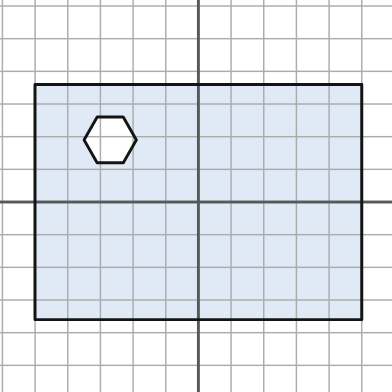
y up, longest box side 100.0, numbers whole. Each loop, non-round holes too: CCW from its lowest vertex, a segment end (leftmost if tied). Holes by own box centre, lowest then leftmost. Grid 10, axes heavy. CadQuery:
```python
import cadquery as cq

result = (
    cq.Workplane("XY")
    .moveTo(-50.0, -36.0)
    .lineTo(50.0, -36.0)
    .lineTo(50.0, 36.0)
    .lineTo(-50.0, 36.0)
    .close()
    .moveTo(-31.0, 12.0)
    .lineTo(-23.0, 12.0)
    .lineTo(-19.0, 19.0)
    .lineTo(-23.0, 26.0)
    .lineTo(-31.0, 26.0)
    .lineTo(-35.0, 19.0)
    .close()
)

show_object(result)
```